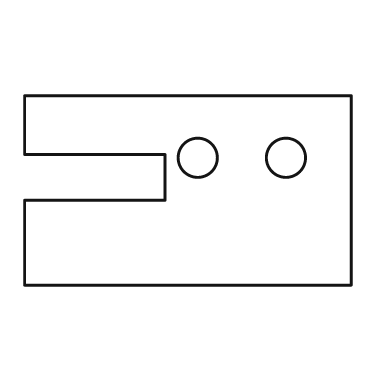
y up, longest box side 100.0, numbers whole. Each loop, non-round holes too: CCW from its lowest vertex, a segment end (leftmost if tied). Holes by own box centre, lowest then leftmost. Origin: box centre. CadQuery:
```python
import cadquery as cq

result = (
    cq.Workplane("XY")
    .moveTo(-50.0, -29.0)
    .lineTo(50.0, -29.0)
    .lineTo(50.0, 29.0)
    .lineTo(-50.0, 29.0)
    .lineTo(-50.0, 11.0)
    .lineTo(-7.0, 11.0)
    .lineTo(-7.0, -3.0)
    .lineTo(-50.0, -3.0)
    .close()
    .moveTo(3.0, 10.0)
    .circle(6.0)
    .moveTo(30.0, 10.0)
    .circle(6.0)
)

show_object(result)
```